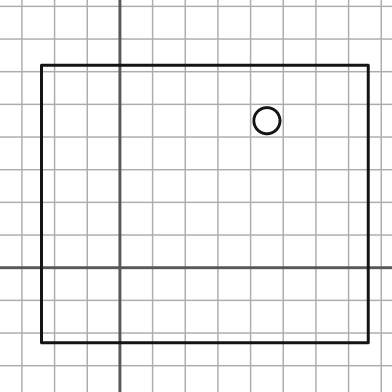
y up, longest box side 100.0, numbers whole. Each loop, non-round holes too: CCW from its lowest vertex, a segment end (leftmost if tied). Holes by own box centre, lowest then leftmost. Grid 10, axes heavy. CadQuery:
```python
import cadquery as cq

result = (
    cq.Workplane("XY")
    .moveTo(-24.0, -23.0)
    .lineTo(76.0, -23.0)
    .lineTo(76.0, 62.0)
    .lineTo(-24.0, 62.0)
    .close()
    .moveTo(45.0, 45.0)
    .circle(4.0)
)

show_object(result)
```